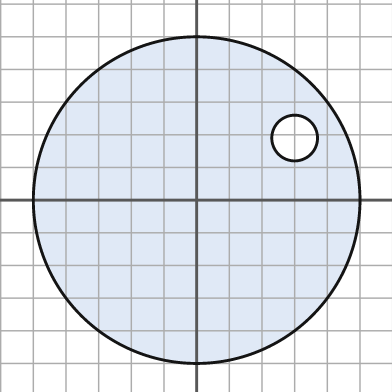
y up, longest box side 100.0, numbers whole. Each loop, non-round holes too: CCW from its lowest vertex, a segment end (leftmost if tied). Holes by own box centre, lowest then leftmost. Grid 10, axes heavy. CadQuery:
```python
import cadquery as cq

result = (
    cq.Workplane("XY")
    .moveTo(0.0, 0.0)
    .circle(50.0)
    .moveTo(30.0, 19.0)
    .circle(7.0)
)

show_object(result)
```